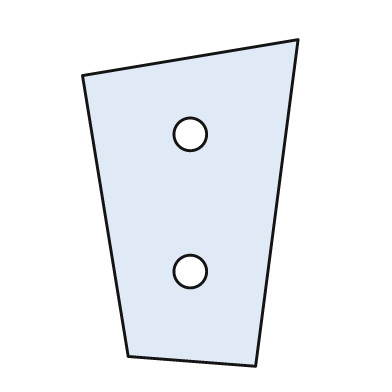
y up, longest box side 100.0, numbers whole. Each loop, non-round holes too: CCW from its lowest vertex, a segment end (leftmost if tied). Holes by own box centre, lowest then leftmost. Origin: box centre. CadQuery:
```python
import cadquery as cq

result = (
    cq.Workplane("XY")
    .moveTo(20.0, -50.0)
    .lineTo(33.0, 50.0)
    .lineTo(-33.0, 39.0)
    .lineTo(-19.0, -47.0)
    .close()
    .moveTo(0.0, -21.0)
    .circle(5.0)
    .moveTo(0.0, 21.0)
    .circle(5.0)
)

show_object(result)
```